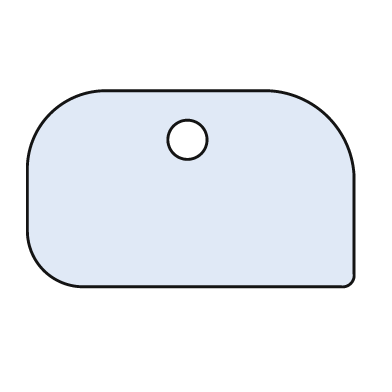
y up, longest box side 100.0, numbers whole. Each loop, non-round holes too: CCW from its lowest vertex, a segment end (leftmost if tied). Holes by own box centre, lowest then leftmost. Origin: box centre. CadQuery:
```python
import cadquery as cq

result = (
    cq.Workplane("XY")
    .moveTo(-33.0, -30.0)
    .lineTo(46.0, -30.0)
    .threePointArc((49.0, -29.0), (50.0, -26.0))
    .lineTo(50.0, 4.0)
    .threePointArc((42.0, 22.0), (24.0, 30.0))
    .lineTo(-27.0, 30.0)
    .threePointArc((-43.0, 23.0), (-50.0, 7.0))
    .lineTo(-50.0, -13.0)
    .threePointArc((-45.0, -25.0), (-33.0, -30.0))
    .close()
    .moveTo(-1.0, 15.0)
    .circle(6.0)
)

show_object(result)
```